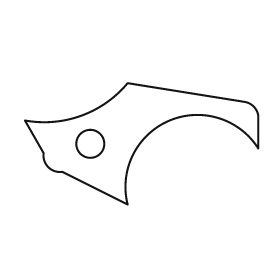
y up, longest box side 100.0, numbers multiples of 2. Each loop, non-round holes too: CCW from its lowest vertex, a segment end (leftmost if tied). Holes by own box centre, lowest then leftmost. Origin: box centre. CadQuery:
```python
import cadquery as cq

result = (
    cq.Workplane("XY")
    .moveTo(-6.0, -26.0)
    .threePointArc((12.0, 10.0), (50.0, -2.0))
    .lineTo(50.0, 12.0)
    .threePointArc((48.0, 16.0), (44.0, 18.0))
    .lineTo(-6.0, 26.0)
    .threePointArc((-26.0, 12.0), (-50.0, 10.0))
    .lineTo(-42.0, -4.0)
    .threePointArc((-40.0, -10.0), (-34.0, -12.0))
    .close()
    .moveTo(-22.0, 0.0)
    .circle(6.0)
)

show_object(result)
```